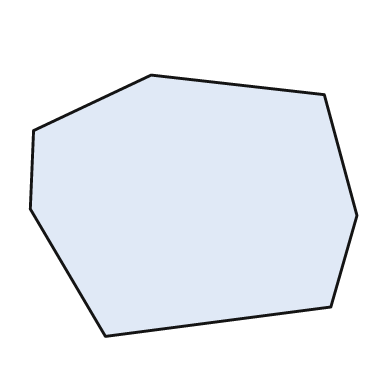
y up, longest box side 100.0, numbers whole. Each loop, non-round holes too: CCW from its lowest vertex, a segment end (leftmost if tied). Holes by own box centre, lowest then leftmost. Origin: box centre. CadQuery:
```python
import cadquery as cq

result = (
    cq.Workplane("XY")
    .moveTo(-27.0, -40.0)
    .lineTo(42.0, -31.0)
    .lineTo(50.0, -3.0)
    .lineTo(40.0, 34.0)
    .lineTo(-13.0, 40.0)
    .lineTo(-49.0, 23.0)
    .lineTo(-50.0, -1.0)
    .close()
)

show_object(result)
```